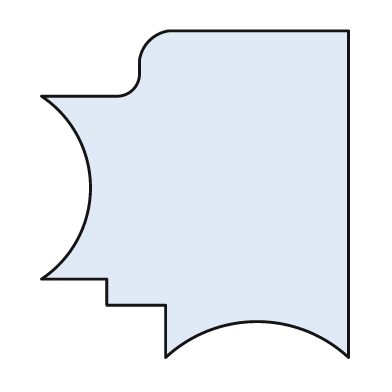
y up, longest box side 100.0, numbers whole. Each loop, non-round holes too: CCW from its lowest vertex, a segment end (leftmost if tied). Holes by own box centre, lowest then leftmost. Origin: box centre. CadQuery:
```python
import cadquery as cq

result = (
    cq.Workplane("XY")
    .moveTo(-9.0, -50.0)
    .threePointArc((19.0, -39.0), (47.0, -50.0))
    .lineTo(47.0, 50.0)
    .lineTo(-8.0, 50.0)
    .threePointArc((-14.0, 47.0), (-17.0, 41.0))
    .lineTo(-17.0, 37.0)
    .threePointArc((-19.0, 32.0), (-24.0, 30.0))
    .lineTo(-47.0, 30.0)
    .threePointArc((-32.0, 2.0), (-47.0, -26.0))
    .lineTo(-27.0, -26.0)
    .lineTo(-27.0, -34.0)
    .lineTo(-9.0, -34.0)
    .close()
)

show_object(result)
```